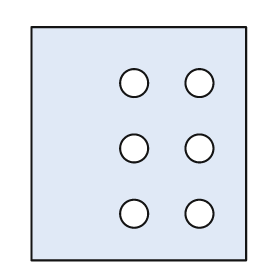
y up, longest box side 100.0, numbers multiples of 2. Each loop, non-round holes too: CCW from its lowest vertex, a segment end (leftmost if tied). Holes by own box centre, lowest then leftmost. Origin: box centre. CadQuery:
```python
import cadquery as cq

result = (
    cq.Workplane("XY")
    .moveTo(-46.0, -50.0)
    .lineTo(46.0, -50.0)
    .lineTo(46.0, 50.0)
    .lineTo(-46.0, 50.0)
    .close()
    .moveTo(-2.0, -30.0)
    .circle(6.0)
    .moveTo(26.0, -30.0)
    .circle(6.0)
    .moveTo(-2.0, -2.0)
    .circle(6.0)
    .moveTo(26.0, -2.0)
    .circle(6.0)
    .moveTo(-2.0, 26.0)
    .circle(6.0)
    .moveTo(26.0, 26.0)
    .circle(6.0)
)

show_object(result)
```